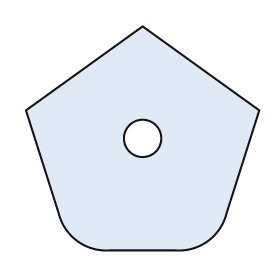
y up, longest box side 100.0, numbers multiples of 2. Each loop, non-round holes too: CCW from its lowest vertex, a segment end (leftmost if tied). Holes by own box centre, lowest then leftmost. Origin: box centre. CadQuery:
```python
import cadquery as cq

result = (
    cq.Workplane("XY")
    .moveTo(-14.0, -48.0)
    .lineTo(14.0, -48.0)
    .threePointArc((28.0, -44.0), (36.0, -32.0))
    .lineTo(50.0, 12.0)
    .lineTo(0.0, 48.0)
    .lineTo(-50.0, 12.0)
    .lineTo(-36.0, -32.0)
    .threePointArc((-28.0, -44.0), (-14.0, -48.0))
    .close()
    .moveTo(0.0, 0.0)
    .circle(8.0)
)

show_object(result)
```